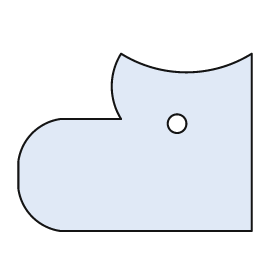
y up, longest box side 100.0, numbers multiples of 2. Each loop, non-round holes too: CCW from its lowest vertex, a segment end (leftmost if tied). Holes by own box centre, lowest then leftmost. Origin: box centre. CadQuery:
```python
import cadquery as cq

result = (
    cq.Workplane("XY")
    .moveTo(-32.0, -38.0)
    .lineTo(50.0, -38.0)
    .lineTo(50.0, 38.0)
    .threePointArc((22.0, 30.0), (-6.0, 38.0))
    .threePointArc((-10.0, 24.0), (-6.0, 10.0))
    .lineTo(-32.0, 10.0)
    .threePointArc((-44.0, 4.0), (-50.0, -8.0))
    .lineTo(-50.0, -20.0)
    .threePointArc((-44.0, -32.0), (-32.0, -38.0))
    .close()
    .moveTo(18.0, 8.0)
    .circle(4.0)
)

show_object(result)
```